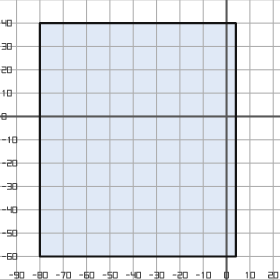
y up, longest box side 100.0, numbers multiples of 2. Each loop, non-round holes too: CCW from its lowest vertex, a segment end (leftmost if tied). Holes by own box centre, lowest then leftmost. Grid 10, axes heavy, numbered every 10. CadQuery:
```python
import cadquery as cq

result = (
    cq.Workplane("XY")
    .moveTo(-80.0, -60.0)
    .lineTo(4.0, -60.0)
    .lineTo(4.0, 40.0)
    .lineTo(-80.0, 40.0)
    .close()
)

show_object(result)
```